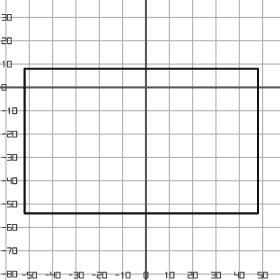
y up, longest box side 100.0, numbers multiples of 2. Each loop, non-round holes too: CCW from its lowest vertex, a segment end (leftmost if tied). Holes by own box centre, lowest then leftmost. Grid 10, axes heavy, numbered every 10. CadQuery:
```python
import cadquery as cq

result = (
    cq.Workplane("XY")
    .moveTo(-52.0, -54.0)
    .lineTo(48.0, -54.0)
    .lineTo(48.0, 8.0)
    .lineTo(-52.0, 8.0)
    .close()
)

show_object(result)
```